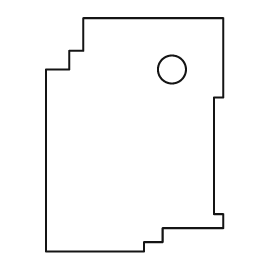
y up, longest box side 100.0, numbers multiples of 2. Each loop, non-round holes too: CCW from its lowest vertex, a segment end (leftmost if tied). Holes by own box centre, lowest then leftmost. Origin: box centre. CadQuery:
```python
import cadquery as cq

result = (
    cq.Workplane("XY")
    .moveTo(-38.0, -50.0)
    .lineTo(4.0, -50.0)
    .lineTo(4.0, -46.0)
    .lineTo(12.0, -46.0)
    .lineTo(12.0, -40.0)
    .lineTo(38.0, -40.0)
    .lineTo(38.0, -34.0)
    .lineTo(34.0, -34.0)
    .lineTo(34.0, 16.0)
    .lineTo(38.0, 16.0)
    .lineTo(38.0, 50.0)
    .lineTo(-22.0, 50.0)
    .lineTo(-22.0, 36.0)
    .lineTo(-28.0, 36.0)
    .lineTo(-28.0, 28.0)
    .lineTo(-38.0, 28.0)
    .close()
    .moveTo(16.0, 28.0)
    .circle(6.0)
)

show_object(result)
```